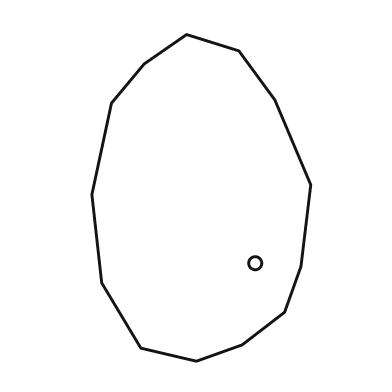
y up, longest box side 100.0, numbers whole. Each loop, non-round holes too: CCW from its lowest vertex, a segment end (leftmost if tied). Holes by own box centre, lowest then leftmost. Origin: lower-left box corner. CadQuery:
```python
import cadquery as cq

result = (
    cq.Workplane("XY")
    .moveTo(32.0, 0.0)
    .lineTo(46.0, 5.0)
    .lineTo(59.0, 15.0)
    .lineTo(64.0, 29.0)
    .lineTo(67.0, 54.0)
    .lineTo(56.0, 80.0)
    .lineTo(45.0, 95.0)
    .lineTo(29.0, 100.0)
    .lineTo(16.0, 91.0)
    .lineTo(6.0, 79.0)
    .lineTo(0.0, 51.0)
    .lineTo(3.0, 24.0)
    .lineTo(15.0, 4.0)
    .close()
    .moveTo(50.0, 30.0)
    .circle(2.0)
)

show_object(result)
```